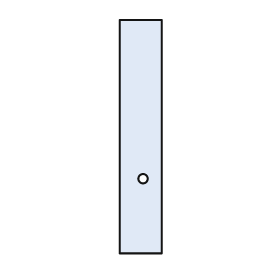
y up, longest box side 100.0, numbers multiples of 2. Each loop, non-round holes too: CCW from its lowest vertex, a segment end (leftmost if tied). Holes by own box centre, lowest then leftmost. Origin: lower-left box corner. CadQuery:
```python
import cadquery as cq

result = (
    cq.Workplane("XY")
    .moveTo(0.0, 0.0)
    .lineTo(18.0, 0.0)
    .lineTo(18.0, 100.0)
    .lineTo(0.0, 100.0)
    .close()
    .moveTo(10.0, 32.0)
    .circle(2.0)
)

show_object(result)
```